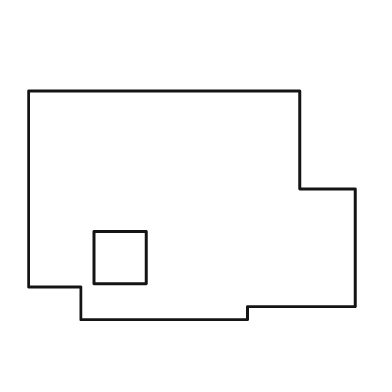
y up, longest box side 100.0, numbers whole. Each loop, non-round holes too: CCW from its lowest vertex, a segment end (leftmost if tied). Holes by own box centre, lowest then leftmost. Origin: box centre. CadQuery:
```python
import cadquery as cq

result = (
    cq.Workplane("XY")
    .moveTo(-34.0, -35.0)
    .lineTo(17.0, -35.0)
    .lineTo(17.0, -31.0)
    .lineTo(50.0, -31.0)
    .lineTo(50.0, 5.0)
    .lineTo(33.0, 5.0)
    .lineTo(33.0, 35.0)
    .lineTo(-50.0, 35.0)
    .lineTo(-50.0, -25.0)
    .lineTo(-34.0, -25.0)
    .close()
    .moveTo(-30.0, -24.0)
    .lineTo(-14.0, -24.0)
    .lineTo(-14.0, -8.0)
    .lineTo(-30.0, -8.0)
    .close()
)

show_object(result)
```